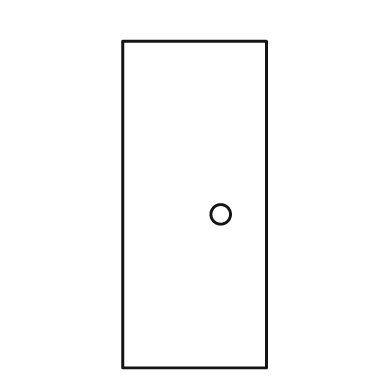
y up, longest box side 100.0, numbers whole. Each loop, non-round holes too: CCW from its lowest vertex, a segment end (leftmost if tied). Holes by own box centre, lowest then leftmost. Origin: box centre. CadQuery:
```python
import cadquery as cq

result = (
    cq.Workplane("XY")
    .moveTo(-22.0, -50.0)
    .lineTo(22.0, -50.0)
    .lineTo(22.0, 50.0)
    .lineTo(-22.0, 50.0)
    .close()
    .moveTo(8.0, -3.0)
    .circle(3.0)
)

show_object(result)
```